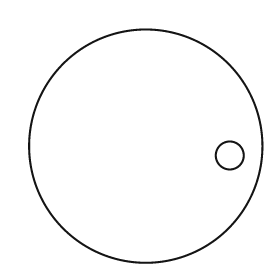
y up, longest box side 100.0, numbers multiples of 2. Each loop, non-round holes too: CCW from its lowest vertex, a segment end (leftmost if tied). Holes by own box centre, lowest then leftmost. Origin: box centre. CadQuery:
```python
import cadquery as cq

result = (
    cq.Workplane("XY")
    .moveTo(0.0, 0.0)
    .circle(50.0)
    .moveTo(36.0, -4.0)
    .circle(6.0)
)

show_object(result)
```